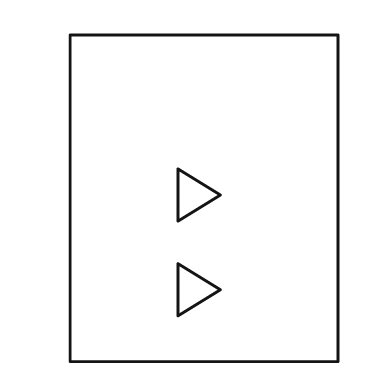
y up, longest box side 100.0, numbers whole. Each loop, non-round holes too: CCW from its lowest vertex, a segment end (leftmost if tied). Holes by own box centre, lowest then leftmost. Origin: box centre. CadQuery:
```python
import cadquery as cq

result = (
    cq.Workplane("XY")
    .moveTo(-41.0, -50.0)
    .lineTo(41.0, -50.0)
    .lineTo(41.0, 50.0)
    .lineTo(-41.0, 50.0)
    .close()
    .moveTo(-8.0, -36.0)
    .lineTo(5.0, -28.0)
    .lineTo(-8.0, -20.0)
    .close()
    .moveTo(-8.0, -7.0)
    .lineTo(5.0, 1.0)
    .lineTo(-8.0, 9.0)
    .close()
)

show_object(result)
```